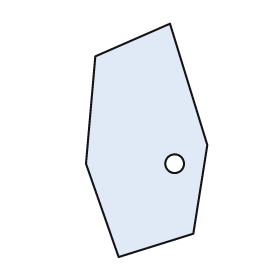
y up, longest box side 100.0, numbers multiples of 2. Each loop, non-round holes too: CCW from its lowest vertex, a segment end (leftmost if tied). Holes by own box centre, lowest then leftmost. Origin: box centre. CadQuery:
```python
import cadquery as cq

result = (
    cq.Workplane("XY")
    .moveTo(-12.0, -50.0)
    .lineTo(20.0, -40.0)
    .lineTo(26.0, -2.0)
    .lineTo(10.0, 50.0)
    .lineTo(-22.0, 36.0)
    .lineTo(-26.0, -10.0)
    .close()
    .moveTo(12.0, -10.0)
    .circle(4.0)
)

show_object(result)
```